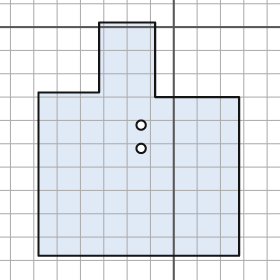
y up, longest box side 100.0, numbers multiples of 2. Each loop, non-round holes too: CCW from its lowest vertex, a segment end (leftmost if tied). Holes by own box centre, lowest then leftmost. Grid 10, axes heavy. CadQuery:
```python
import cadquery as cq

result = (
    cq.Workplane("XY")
    .moveTo(-58.0, -98.0)
    .lineTo(28.0, -98.0)
    .lineTo(28.0, -30.0)
    .lineTo(-8.0, -30.0)
    .lineTo(-8.0, 2.0)
    .lineTo(-32.0, 2.0)
    .lineTo(-32.0, -28.0)
    .lineTo(-58.0, -28.0)
    .close()
    .moveTo(-14.0, -52.0)
    .circle(2.0)
    .moveTo(-14.0, -42.0)
    .circle(2.0)
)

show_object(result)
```